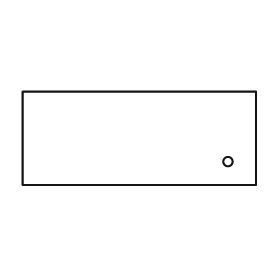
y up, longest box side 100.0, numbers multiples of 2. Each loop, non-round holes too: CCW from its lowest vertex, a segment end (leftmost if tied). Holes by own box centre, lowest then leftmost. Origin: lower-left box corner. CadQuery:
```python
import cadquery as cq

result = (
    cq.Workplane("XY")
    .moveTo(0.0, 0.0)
    .lineTo(100.0, 0.0)
    .lineTo(100.0, 40.0)
    .lineTo(0.0, 40.0)
    .close()
    .moveTo(88.0, 10.0)
    .circle(2.0)
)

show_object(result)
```